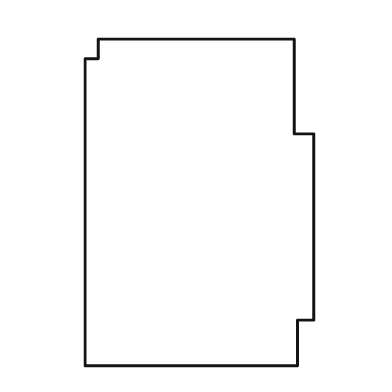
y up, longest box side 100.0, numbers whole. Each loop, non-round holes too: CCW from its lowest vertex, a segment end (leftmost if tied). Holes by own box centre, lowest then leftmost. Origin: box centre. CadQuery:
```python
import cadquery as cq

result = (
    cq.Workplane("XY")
    .moveTo(-35.0, -50.0)
    .lineTo(30.0, -50.0)
    .lineTo(30.0, -36.0)
    .lineTo(35.0, -36.0)
    .lineTo(35.0, 21.0)
    .lineTo(29.0, 21.0)
    .lineTo(29.0, 50.0)
    .lineTo(-31.0, 50.0)
    .lineTo(-31.0, 44.0)
    .lineTo(-35.0, 44.0)
    .close()
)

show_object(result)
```